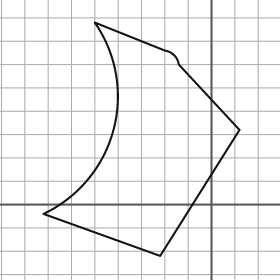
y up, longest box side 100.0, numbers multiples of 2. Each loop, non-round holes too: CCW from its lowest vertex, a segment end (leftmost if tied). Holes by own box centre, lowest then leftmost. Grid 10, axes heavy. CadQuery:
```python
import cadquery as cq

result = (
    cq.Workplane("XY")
    .moveTo(-22.0, -22.0)
    .lineTo(12.0, 32.0)
    .lineTo(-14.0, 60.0)
    .threePointArc((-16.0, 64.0), (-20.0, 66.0))
    .lineTo(-50.0, 78.0)
    .threePointArc((-42.0, 32.0), (-72.0, -4.0))
    .close()
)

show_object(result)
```